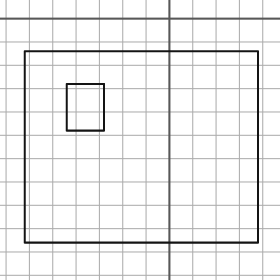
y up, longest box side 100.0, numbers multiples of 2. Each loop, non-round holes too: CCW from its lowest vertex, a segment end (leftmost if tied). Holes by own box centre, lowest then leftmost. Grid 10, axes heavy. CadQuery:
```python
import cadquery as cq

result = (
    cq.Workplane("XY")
    .moveTo(-62.0, -96.0)
    .lineTo(38.0, -96.0)
    .lineTo(38.0, -14.0)
    .lineTo(-62.0, -14.0)
    .close()
    .moveTo(-44.0, -48.0)
    .lineTo(-28.0, -48.0)
    .lineTo(-28.0, -28.0)
    .lineTo(-44.0, -28.0)
    .close()
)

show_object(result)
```